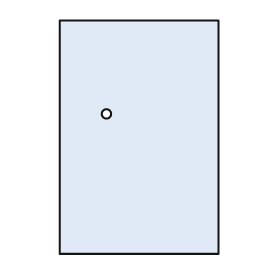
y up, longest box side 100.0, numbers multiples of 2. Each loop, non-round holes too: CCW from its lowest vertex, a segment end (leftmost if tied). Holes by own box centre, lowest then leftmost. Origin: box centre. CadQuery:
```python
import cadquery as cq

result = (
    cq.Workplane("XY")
    .moveTo(-34.0, -50.0)
    .lineTo(34.0, -50.0)
    .lineTo(34.0, 50.0)
    .lineTo(-34.0, 50.0)
    .close()
    .moveTo(-14.0, 10.0)
    .circle(2.0)
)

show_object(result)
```